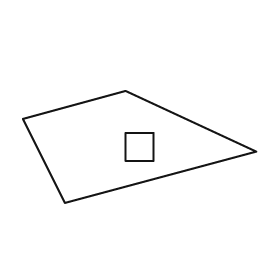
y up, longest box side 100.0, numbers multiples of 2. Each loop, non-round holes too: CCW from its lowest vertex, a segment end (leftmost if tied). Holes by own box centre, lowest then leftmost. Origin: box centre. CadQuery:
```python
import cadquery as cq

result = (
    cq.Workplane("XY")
    .moveTo(-32.0, -24.0)
    .lineTo(50.0, -2.0)
    .lineTo(-6.0, 24.0)
    .lineTo(-50.0, 12.0)
    .close()
    .moveTo(-6.0, -6.0)
    .lineTo(6.0, -6.0)
    .lineTo(6.0, 6.0)
    .lineTo(-6.0, 6.0)
    .close()
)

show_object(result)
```